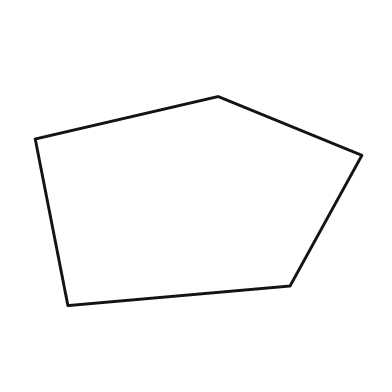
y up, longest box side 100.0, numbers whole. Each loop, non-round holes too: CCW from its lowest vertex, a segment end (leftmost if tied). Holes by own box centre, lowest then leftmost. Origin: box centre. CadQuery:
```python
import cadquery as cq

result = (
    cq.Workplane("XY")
    .moveTo(-40.0, -32.0)
    .lineTo(28.0, -26.0)
    .lineTo(50.0, 14.0)
    .lineTo(6.0, 32.0)
    .lineTo(-50.0, 19.0)
    .close()
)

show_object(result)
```